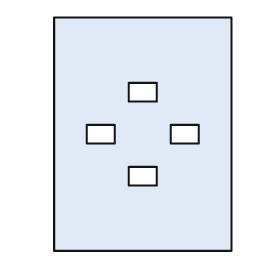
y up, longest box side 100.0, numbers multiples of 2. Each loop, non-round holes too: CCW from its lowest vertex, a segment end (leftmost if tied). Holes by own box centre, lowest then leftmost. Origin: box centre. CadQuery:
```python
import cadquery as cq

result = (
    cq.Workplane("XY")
    .moveTo(-38.0, -50.0)
    .lineTo(38.0, -50.0)
    .lineTo(38.0, 50.0)
    .lineTo(-38.0, 50.0)
    .close()
    .moveTo(-6.0, -22.0)
    .lineTo(6.0, -22.0)
    .lineTo(6.0, -14.0)
    .lineTo(-6.0, -14.0)
    .close()
    .moveTo(-24.0, -4.0)
    .lineTo(-12.0, -4.0)
    .lineTo(-12.0, 4.0)
    .lineTo(-24.0, 4.0)
    .close()
    .moveTo(12.0, -4.0)
    .lineTo(24.0, -4.0)
    .lineTo(24.0, 4.0)
    .lineTo(12.0, 4.0)
    .close()
    .moveTo(-6.0, 14.0)
    .lineTo(6.0, 14.0)
    .lineTo(6.0, 22.0)
    .lineTo(-6.0, 22.0)
    .close()
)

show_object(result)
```